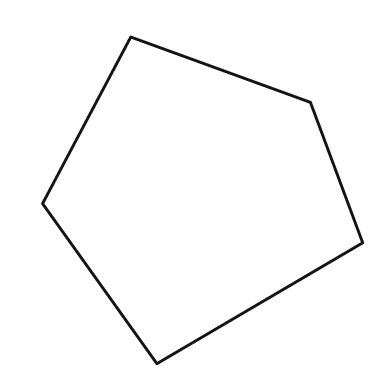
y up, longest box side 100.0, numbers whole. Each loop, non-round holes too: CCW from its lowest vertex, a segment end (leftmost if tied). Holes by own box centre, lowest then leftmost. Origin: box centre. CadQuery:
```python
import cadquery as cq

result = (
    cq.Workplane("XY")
    .moveTo(-14.0, -50.0)
    .lineTo(49.0, -13.0)
    .lineTo(33.0, 30.0)
    .lineTo(-22.0, 50.0)
    .lineTo(-49.0, -1.0)
    .close()
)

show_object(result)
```